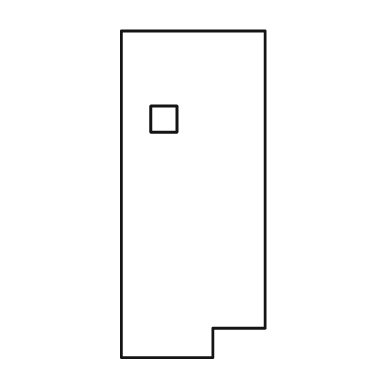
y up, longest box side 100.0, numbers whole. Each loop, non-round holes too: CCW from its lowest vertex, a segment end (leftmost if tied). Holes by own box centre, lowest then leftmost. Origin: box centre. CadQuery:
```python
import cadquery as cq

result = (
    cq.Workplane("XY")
    .moveTo(-22.0, -50.0)
    .lineTo(6.0, -50.0)
    .lineTo(6.0, -41.0)
    .lineTo(22.0, -41.0)
    .lineTo(22.0, 50.0)
    .lineTo(-22.0, 50.0)
    .close()
    .moveTo(-13.0, 19.0)
    .lineTo(-5.0, 19.0)
    .lineTo(-5.0, 27.0)
    .lineTo(-13.0, 27.0)
    .close()
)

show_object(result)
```